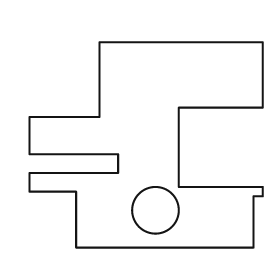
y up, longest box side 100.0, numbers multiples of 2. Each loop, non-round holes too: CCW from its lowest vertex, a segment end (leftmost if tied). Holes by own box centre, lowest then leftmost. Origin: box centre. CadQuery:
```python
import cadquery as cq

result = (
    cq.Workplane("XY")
    .moveTo(-30.0, -44.0)
    .lineTo(46.0, -44.0)
    .lineTo(46.0, -22.0)
    .lineTo(50.0, -22.0)
    .lineTo(50.0, -18.0)
    .lineTo(14.0, -18.0)
    .lineTo(14.0, 16.0)
    .lineTo(50.0, 16.0)
    .lineTo(50.0, 44.0)
    .lineTo(-20.0, 44.0)
    .lineTo(-20.0, 12.0)
    .lineTo(-50.0, 12.0)
    .lineTo(-50.0, -4.0)
    .lineTo(-12.0, -4.0)
    .lineTo(-12.0, -12.0)
    .lineTo(-50.0, -12.0)
    .lineTo(-50.0, -20.0)
    .lineTo(-30.0, -20.0)
    .close()
    .moveTo(4.0, -28.0)
    .circle(10.0)
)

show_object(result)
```